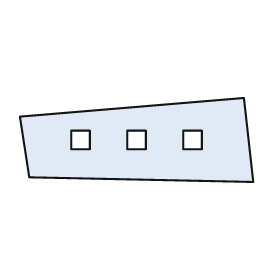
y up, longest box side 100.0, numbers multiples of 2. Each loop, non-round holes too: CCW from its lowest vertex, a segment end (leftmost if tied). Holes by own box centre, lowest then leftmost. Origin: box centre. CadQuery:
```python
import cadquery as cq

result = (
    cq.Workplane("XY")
    .moveTo(50.0, -18.0)
    .lineTo(46.0, 18.0)
    .lineTo(-50.0, 10.0)
    .lineTo(-46.0, -16.0)
    .close()
    .moveTo(-28.0, -4.0)
    .lineTo(-20.0, -4.0)
    .lineTo(-20.0, 4.0)
    .lineTo(-28.0, 4.0)
    .close()
    .moveTo(-4.0, -4.0)
    .lineTo(4.0, -4.0)
    .lineTo(4.0, 4.0)
    .lineTo(-4.0, 4.0)
    .close()
    .moveTo(20.0, -4.0)
    .lineTo(28.0, -4.0)
    .lineTo(28.0, 4.0)
    .lineTo(20.0, 4.0)
    .close()
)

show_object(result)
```